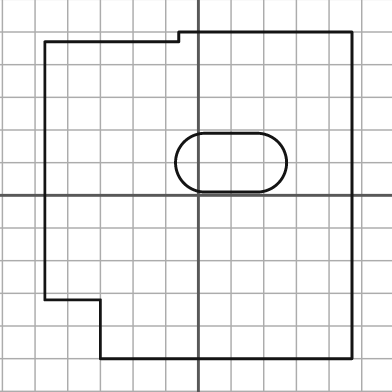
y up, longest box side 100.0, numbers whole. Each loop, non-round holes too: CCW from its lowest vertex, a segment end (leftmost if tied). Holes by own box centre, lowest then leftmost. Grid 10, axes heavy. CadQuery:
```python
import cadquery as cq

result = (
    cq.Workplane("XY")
    .moveTo(-30.0, -50.0)
    .lineTo(47.0, -50.0)
    .lineTo(47.0, 50.0)
    .lineTo(-6.0, 50.0)
    .lineTo(-6.0, 47.0)
    .lineTo(-47.0, 47.0)
    .lineTo(-47.0, -32.0)
    .lineTo(-30.0, -32.0)
    .close()
    .moveTo(2.0, 1.0)
    .lineTo(18.0, 1.0)
    .threePointArc((27.0, 10.0), (18.0, 19.0))
    .lineTo(2.0, 19.0)
    .threePointArc((-7.0, 10.0), (2.0, 1.0))
    .close()
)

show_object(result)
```